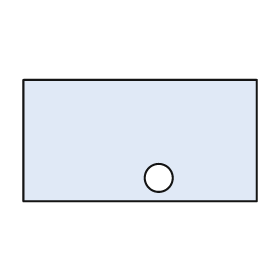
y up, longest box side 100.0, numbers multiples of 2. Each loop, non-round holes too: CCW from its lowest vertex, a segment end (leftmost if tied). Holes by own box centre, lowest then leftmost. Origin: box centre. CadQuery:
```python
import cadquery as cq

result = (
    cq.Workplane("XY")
    .moveTo(-50.0, -26.0)
    .lineTo(50.0, -26.0)
    .lineTo(50.0, 26.0)
    .lineTo(-50.0, 26.0)
    .close()
    .moveTo(8.0, -16.0)
    .circle(6.0)
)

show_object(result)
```